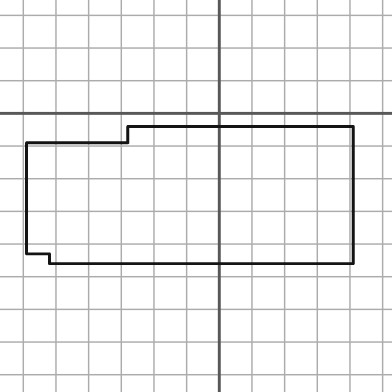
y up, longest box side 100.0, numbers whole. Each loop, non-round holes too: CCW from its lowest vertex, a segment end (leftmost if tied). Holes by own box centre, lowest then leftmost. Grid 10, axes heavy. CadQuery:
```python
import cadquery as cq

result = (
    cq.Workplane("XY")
    .moveTo(-52.0, -46.0)
    .lineTo(41.0, -46.0)
    .lineTo(41.0, -4.0)
    .lineTo(-28.0, -4.0)
    .lineTo(-28.0, -9.0)
    .lineTo(-59.0, -9.0)
    .lineTo(-59.0, -43.0)
    .lineTo(-52.0, -43.0)
    .close()
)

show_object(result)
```